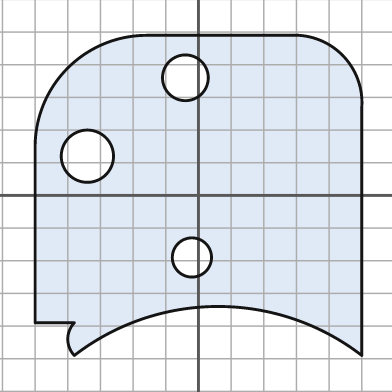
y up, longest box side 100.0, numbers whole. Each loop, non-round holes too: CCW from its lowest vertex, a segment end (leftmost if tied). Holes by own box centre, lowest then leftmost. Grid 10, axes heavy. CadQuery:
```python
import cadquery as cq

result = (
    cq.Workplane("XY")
    .moveTo(-38.0, -49.0)
    .threePointArc((6.0, -34.0), (50.0, -49.0))
    .lineTo(50.0, 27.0)
    .threePointArc((44.0, 43.0), (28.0, 49.0))
    .lineTo(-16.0, 49.0)
    .threePointArc((-40.0, 39.0), (-50.0, 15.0))
    .lineTo(-50.0, -39.0)
    .lineTo(-38.0, -39.0)
    .threePointArc((-40.0, -44.0), (-38.0, -49.0))
    .close()
    .moveTo(-2.0, -19.0)
    .circle(6.0)
    .moveTo(-34.0, 12.0)
    .circle(8.0)
    .moveTo(-4.0, 36.0)
    .circle(7.0)
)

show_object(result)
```